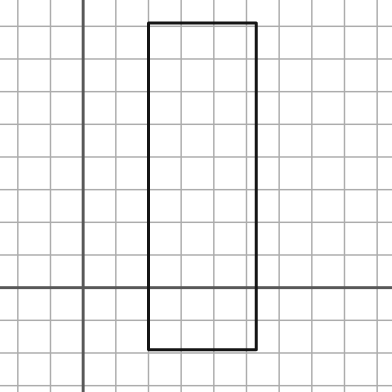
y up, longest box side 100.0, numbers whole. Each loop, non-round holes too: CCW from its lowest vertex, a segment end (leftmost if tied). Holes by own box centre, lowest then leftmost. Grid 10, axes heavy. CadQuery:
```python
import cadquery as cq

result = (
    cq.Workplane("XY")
    .moveTo(20.0, -19.0)
    .lineTo(53.0, -19.0)
    .lineTo(53.0, 81.0)
    .lineTo(20.0, 81.0)
    .close()
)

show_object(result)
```